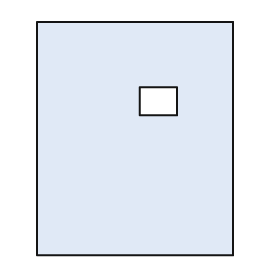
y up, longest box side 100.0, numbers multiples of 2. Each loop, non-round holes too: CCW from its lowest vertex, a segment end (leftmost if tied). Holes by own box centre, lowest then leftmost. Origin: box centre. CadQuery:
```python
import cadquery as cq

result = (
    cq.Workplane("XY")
    .moveTo(-42.0, -50.0)
    .lineTo(42.0, -50.0)
    .lineTo(42.0, 50.0)
    .lineTo(-42.0, 50.0)
    .close()
    .moveTo(2.0, 10.0)
    .lineTo(18.0, 10.0)
    .lineTo(18.0, 22.0)
    .lineTo(2.0, 22.0)
    .close()
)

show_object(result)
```